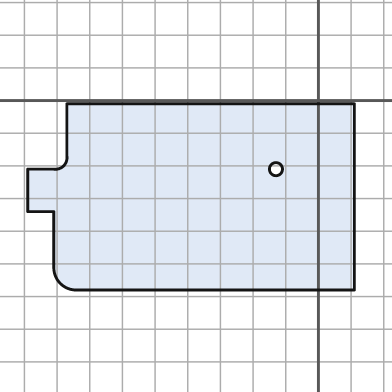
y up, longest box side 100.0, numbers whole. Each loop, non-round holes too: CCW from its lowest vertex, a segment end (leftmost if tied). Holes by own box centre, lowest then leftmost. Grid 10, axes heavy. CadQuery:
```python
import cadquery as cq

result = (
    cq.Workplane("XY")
    .moveTo(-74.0, -58.0)
    .lineTo(11.0, -58.0)
    .lineTo(11.0, -1.0)
    .lineTo(-77.0, -1.0)
    .lineTo(-77.0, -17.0)
    .threePointArc((-78.0, -20.0), (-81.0, -21.0))
    .lineTo(-89.0, -21.0)
    .lineTo(-89.0, -34.0)
    .lineTo(-81.0, -34.0)
    .lineTo(-81.0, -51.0)
    .threePointArc((-79.0, -56.0), (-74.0, -58.0))
    .close()
    .moveTo(-13.0, -21.0)
    .circle(2.0)
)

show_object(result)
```